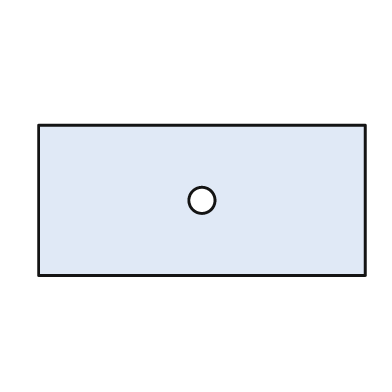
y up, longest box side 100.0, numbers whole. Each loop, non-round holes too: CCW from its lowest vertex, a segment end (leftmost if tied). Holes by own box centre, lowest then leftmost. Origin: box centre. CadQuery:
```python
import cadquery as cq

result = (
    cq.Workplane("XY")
    .moveTo(-50.0, -23.0)
    .lineTo(50.0, -23.0)
    .lineTo(50.0, 23.0)
    .lineTo(-50.0, 23.0)
    .close()
    .moveTo(0.0, 0.0)
    .circle(4.0)
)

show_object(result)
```